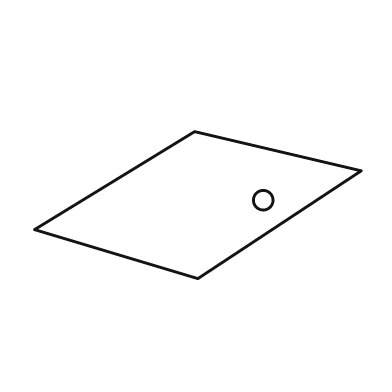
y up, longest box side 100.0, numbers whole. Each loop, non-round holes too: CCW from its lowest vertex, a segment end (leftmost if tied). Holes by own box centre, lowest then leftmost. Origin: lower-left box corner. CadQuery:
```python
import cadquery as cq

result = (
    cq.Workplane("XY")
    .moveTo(50.0, 0.0)
    .lineTo(100.0, 33.0)
    .lineTo(49.0, 45.0)
    .lineTo(0.0, 15.0)
    .close()
    .moveTo(70.0, 24.0)
    .circle(3.0)
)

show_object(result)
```